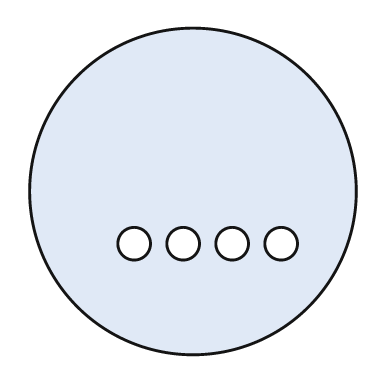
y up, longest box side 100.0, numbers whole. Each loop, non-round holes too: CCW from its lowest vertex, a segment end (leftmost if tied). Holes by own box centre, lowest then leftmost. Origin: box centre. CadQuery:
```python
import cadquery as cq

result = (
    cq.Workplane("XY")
    .moveTo(0.0, 0.0)
    .circle(50.0)
    .moveTo(-18.0, -16.0)
    .circle(5.0)
    .moveTo(-3.0, -16.0)
    .circle(5.0)
    .moveTo(12.0, -16.0)
    .circle(5.0)
    .moveTo(27.0, -16.0)
    .circle(5.0)
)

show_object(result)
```